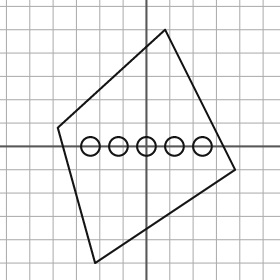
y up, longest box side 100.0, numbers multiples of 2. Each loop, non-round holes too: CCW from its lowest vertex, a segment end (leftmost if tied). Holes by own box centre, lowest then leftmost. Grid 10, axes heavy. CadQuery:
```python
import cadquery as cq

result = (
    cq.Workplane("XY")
    .moveTo(-22.0, -50.0)
    .lineTo(38.0, -10.0)
    .lineTo(8.0, 50.0)
    .lineTo(-38.0, 8.0)
    .close()
    .moveTo(-24.0, 0.0)
    .circle(4.0)
    .moveTo(-12.0, 0.0)
    .circle(4.0)
    .moveTo(0.0, 0.0)
    .circle(4.0)
    .moveTo(12.0, 0.0)
    .circle(4.0)
    .moveTo(24.0, 0.0)
    .circle(4.0)
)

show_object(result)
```